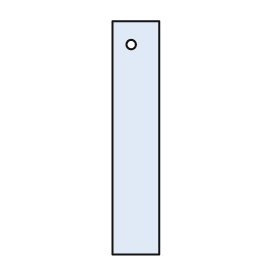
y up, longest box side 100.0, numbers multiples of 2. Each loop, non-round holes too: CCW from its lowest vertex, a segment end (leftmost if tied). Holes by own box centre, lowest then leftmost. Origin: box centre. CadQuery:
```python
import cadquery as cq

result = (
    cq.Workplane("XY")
    .moveTo(-10.0, -50.0)
    .lineTo(10.0, -50.0)
    .lineTo(10.0, 50.0)
    .lineTo(-10.0, 50.0)
    .close()
    .moveTo(-2.0, 40.0)
    .circle(2.0)
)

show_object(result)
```